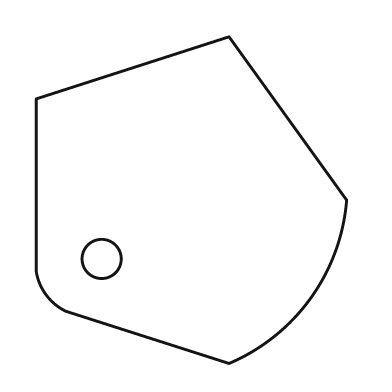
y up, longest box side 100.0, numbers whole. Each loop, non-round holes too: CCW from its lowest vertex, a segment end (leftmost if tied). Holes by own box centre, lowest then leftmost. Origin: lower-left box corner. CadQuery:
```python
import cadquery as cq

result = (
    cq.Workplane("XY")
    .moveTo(59.0, 0.0)
    .threePointArc((84.0, 20.0), (95.0, 50.0))
    .lineTo(59.0, 100.0)
    .lineTo(0.0, 81.0)
    .lineTo(0.0, 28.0)
    .threePointArc((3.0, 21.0), (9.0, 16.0))
    .close()
    .moveTo(20.0, 32.0)
    .circle(6.0)
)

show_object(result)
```